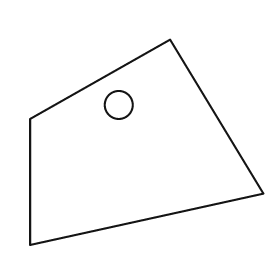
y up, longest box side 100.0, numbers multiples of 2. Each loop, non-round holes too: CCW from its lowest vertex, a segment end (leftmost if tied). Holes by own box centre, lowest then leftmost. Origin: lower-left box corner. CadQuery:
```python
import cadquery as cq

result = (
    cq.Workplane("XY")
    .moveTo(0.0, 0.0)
    .lineTo(100.0, 22.0)
    .lineTo(60.0, 88.0)
    .lineTo(0.0, 54.0)
    .close()
    .moveTo(38.0, 60.0)
    .circle(6.0)
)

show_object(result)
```